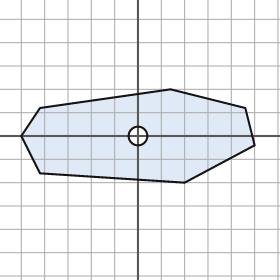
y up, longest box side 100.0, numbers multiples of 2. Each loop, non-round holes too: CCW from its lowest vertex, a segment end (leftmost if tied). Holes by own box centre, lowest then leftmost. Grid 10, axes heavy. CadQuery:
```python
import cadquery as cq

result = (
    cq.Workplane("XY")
    .moveTo(20.0, -20.0)
    .lineTo(50.0, -4.0)
    .lineTo(46.0, 12.0)
    .lineTo(14.0, 20.0)
    .lineTo(-42.0, 12.0)
    .lineTo(-50.0, 0.0)
    .lineTo(-42.0, -16.0)
    .close()
    .moveTo(0.0, 0.0)
    .circle(4.0)
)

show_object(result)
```